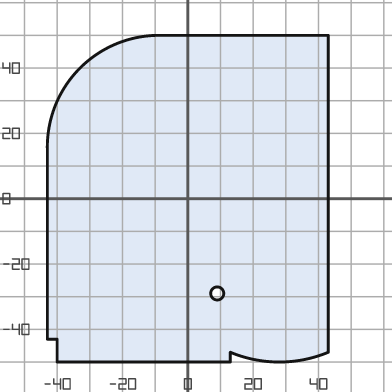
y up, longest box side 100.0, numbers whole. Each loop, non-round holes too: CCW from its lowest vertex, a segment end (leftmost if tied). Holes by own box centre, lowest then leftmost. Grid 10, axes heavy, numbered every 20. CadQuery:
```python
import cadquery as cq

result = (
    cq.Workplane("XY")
    .moveTo(-40.0, -50.0)
    .lineTo(13.0, -50.0)
    .lineTo(13.0, -47.0)
    .threePointArc((28.0, -50.0), (43.0, -47.0))
    .lineTo(43.0, 50.0)
    .lineTo(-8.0, 50.0)
    .threePointArc((-33.0, 40.0), (-43.0, 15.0))
    .lineTo(-43.0, -43.0)
    .lineTo(-40.0, -43.0)
    .close()
    .moveTo(9.0, -29.0)
    .circle(2.0)
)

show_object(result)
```